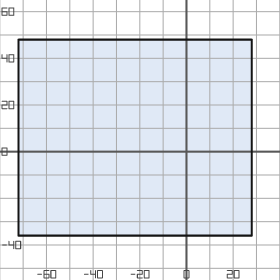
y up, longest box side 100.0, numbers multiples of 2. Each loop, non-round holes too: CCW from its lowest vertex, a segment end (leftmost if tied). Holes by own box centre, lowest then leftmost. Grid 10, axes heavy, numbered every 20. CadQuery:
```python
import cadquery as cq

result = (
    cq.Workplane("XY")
    .moveTo(-72.0, -36.0)
    .lineTo(28.0, -36.0)
    .lineTo(28.0, 48.0)
    .lineTo(-72.0, 48.0)
    .close()
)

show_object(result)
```